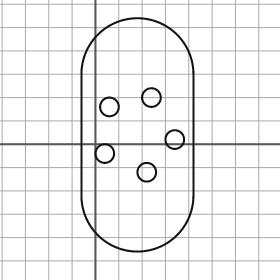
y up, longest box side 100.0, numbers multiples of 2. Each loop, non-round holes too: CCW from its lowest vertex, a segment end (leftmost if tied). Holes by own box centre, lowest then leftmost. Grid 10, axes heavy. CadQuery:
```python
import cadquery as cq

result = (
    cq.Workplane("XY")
    .moveTo(-6.0, -22.0)
    .threePointArc((18.0, -46.0), (42.0, -22.0))
    .lineTo(42.0, 30.0)
    .threePointArc((18.0, 54.0), (-6.0, 30.0))
    .close()
    .moveTo(22.0, -12.0)
    .circle(4.0)
    .moveTo(4.0, -4.0)
    .circle(4.0)
    .moveTo(34.0, 2.0)
    .circle(4.0)
    .moveTo(6.0, 16.0)
    .circle(4.0)
    .moveTo(24.0, 20.0)
    .circle(4.0)
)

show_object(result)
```